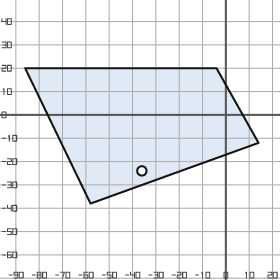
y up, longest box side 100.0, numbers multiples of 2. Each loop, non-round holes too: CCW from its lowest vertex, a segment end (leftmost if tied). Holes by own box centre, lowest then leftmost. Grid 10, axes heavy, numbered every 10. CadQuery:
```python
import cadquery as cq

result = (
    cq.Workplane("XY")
    .moveTo(-58.0, -38.0)
    .lineTo(14.0, -12.0)
    .lineTo(-4.0, 20.0)
    .lineTo(-86.0, 20.0)
    .close()
    .moveTo(-36.0, -24.0)
    .circle(2.0)
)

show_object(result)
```